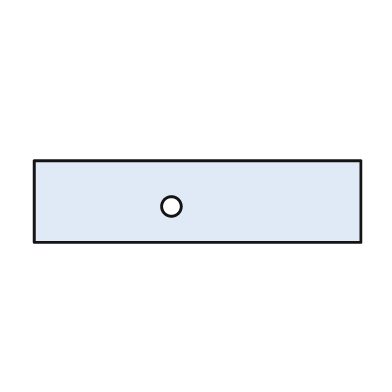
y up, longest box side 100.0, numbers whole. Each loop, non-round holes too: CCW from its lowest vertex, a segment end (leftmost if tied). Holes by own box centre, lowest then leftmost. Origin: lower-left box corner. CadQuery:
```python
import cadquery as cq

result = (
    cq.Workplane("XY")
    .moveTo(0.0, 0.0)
    .lineTo(100.0, 0.0)
    .lineTo(100.0, 25.0)
    .lineTo(0.0, 25.0)
    .close()
    .moveTo(42.0, 11.0)
    .circle(3.0)
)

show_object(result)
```